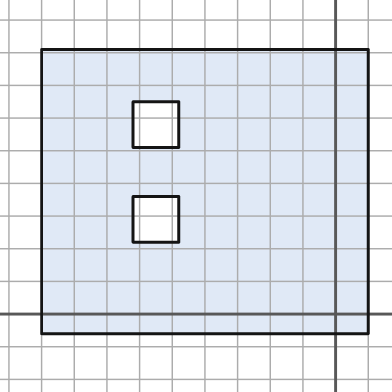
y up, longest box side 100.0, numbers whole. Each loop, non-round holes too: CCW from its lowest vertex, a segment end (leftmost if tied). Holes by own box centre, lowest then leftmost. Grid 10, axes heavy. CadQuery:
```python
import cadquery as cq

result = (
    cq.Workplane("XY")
    .moveTo(-90.0, -6.0)
    .lineTo(10.0, -6.0)
    .lineTo(10.0, 81.0)
    .lineTo(-90.0, 81.0)
    .close()
    .moveTo(-62.0, 22.0)
    .lineTo(-48.0, 22.0)
    .lineTo(-48.0, 36.0)
    .lineTo(-62.0, 36.0)
    .close()
    .moveTo(-62.0, 51.0)
    .lineTo(-48.0, 51.0)
    .lineTo(-48.0, 65.0)
    .lineTo(-62.0, 65.0)
    .close()
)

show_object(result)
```